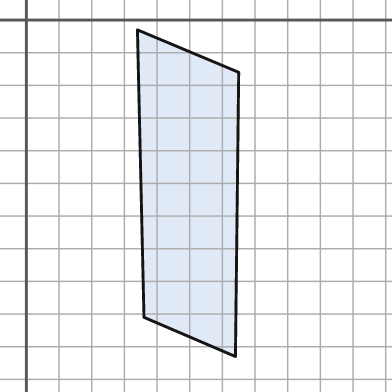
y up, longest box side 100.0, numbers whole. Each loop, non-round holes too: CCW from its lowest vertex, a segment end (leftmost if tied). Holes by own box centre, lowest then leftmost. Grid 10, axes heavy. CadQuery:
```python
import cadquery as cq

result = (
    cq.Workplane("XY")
    .moveTo(64.0, -103.0)
    .lineTo(65.0, -16.0)
    .lineTo(34.0, -3.0)
    .lineTo(36.0, -91.0)
    .close()
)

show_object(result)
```